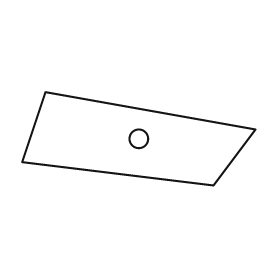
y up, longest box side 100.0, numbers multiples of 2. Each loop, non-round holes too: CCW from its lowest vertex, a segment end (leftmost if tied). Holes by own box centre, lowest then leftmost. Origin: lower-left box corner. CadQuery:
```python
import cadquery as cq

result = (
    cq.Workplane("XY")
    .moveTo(82.0, 0.0)
    .lineTo(100.0, 24.0)
    .lineTo(10.0, 40.0)
    .lineTo(0.0, 10.0)
    .close()
    .moveTo(50.0, 20.0)
    .circle(4.0)
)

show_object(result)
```